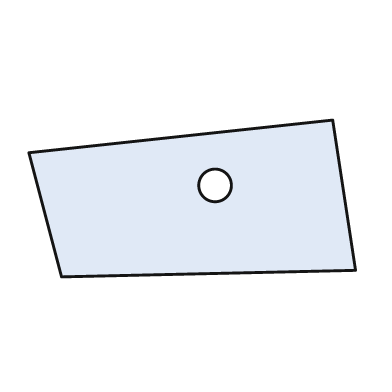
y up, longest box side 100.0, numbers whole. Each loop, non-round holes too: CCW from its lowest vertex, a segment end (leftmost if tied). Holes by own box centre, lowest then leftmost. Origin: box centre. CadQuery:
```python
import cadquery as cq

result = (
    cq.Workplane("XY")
    .moveTo(-40.0, -24.0)
    .lineTo(50.0, -22.0)
    .lineTo(43.0, 24.0)
    .lineTo(-50.0, 14.0)
    .close()
    .moveTo(7.0, 4.0)
    .circle(5.0)
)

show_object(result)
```